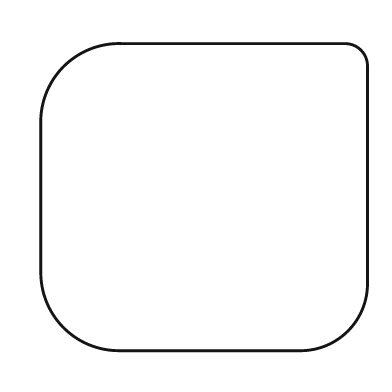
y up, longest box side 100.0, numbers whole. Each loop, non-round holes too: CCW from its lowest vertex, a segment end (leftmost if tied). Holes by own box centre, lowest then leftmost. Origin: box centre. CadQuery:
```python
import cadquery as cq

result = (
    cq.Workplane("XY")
    .moveTo(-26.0, -47.0)
    .lineTo(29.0, -47.0)
    .threePointArc((44.0, -41.0), (50.0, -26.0))
    .lineTo(50.0, 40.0)
    .threePointArc((48.0, 45.0), (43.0, 47.0))
    .lineTo(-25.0, 47.0)
    .threePointArc((-43.0, 40.0), (-50.0, 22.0))
    .lineTo(-50.0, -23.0)
    .threePointArc((-43.0, -40.0), (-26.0, -47.0))
    .close()
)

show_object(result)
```